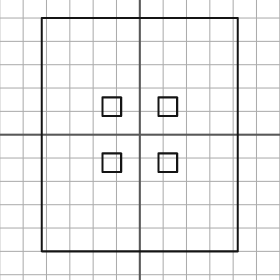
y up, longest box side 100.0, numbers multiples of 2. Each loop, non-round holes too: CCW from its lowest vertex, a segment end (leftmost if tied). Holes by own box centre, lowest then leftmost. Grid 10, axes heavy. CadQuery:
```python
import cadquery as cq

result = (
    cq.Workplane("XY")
    .moveTo(-42.0, -50.0)
    .lineTo(42.0, -50.0)
    .lineTo(42.0, 50.0)
    .lineTo(-42.0, 50.0)
    .close()
    .moveTo(-16.0, -16.0)
    .lineTo(-8.0, -16.0)
    .lineTo(-8.0, -8.0)
    .lineTo(-16.0, -8.0)
    .close()
    .moveTo(8.0, -16.0)
    .lineTo(16.0, -16.0)
    .lineTo(16.0, -8.0)
    .lineTo(8.0, -8.0)
    .close()
    .moveTo(-16.0, 8.0)
    .lineTo(-8.0, 8.0)
    .lineTo(-8.0, 16.0)
    .lineTo(-16.0, 16.0)
    .close()
    .moveTo(8.0, 8.0)
    .lineTo(16.0, 8.0)
    .lineTo(16.0, 16.0)
    .lineTo(8.0, 16.0)
    .close()
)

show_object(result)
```